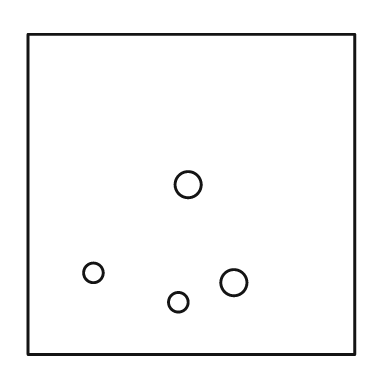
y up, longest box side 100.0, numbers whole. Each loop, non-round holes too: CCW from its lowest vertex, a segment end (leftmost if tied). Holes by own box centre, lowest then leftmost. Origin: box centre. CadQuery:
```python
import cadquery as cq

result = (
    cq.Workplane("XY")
    .moveTo(-50.0, -49.0)
    .lineTo(50.0, -49.0)
    .lineTo(50.0, 49.0)
    .lineTo(-50.0, 49.0)
    .close()
    .moveTo(-4.0, -33.0)
    .circle(3.0)
    .moveTo(13.0, -27.0)
    .circle(4.0)
    .moveTo(-30.0, -24.0)
    .circle(3.0)
    .moveTo(-1.0, 3.0)
    .circle(4.0)
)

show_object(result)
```